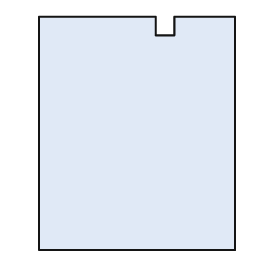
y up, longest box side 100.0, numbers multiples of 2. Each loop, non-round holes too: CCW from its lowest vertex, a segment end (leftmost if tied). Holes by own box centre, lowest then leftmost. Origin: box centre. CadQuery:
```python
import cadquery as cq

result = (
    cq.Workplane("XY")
    .moveTo(-42.0, -50.0)
    .lineTo(42.0, -50.0)
    .lineTo(42.0, 50.0)
    .lineTo(16.0, 50.0)
    .lineTo(16.0, 42.0)
    .lineTo(8.0, 42.0)
    .lineTo(8.0, 50.0)
    .lineTo(-42.0, 50.0)
    .close()
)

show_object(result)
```